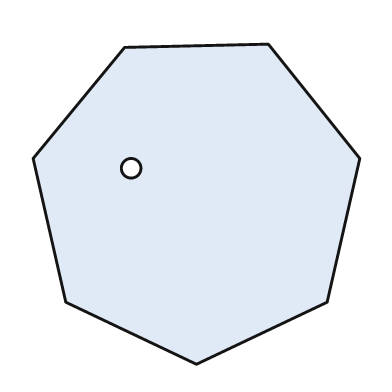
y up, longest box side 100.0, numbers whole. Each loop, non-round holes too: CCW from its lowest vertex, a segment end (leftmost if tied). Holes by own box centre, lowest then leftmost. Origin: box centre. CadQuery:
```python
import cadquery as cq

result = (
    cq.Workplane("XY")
    .moveTo(0.0, -49.0)
    .lineTo(40.0, -30.0)
    .lineTo(50.0, 14.0)
    .lineTo(22.0, 49.0)
    .lineTo(-22.0, 48.0)
    .lineTo(-50.0, 14.0)
    .lineTo(-40.0, -30.0)
    .close()
    .moveTo(-20.0, 11.0)
    .circle(3.0)
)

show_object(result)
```